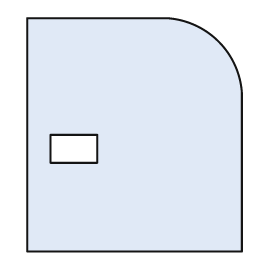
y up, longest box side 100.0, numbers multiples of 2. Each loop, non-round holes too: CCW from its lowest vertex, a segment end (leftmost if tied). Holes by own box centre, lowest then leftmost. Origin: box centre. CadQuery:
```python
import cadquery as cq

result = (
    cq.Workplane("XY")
    .moveTo(-46.0, -50.0)
    .lineTo(46.0, -50.0)
    .lineTo(46.0, 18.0)
    .threePointArc((36.0, 40.0), (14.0, 50.0))
    .lineTo(-46.0, 50.0)
    .close()
    .moveTo(-36.0, -12.0)
    .lineTo(-16.0, -12.0)
    .lineTo(-16.0, 0.0)
    .lineTo(-36.0, 0.0)
    .close()
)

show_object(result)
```